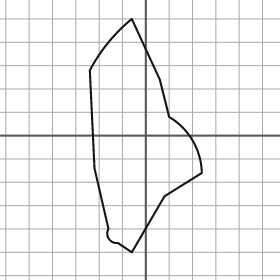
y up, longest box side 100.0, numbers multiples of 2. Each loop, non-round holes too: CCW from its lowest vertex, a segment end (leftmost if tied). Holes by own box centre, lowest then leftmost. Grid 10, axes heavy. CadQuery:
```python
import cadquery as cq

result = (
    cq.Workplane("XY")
    .moveTo(-6.0, -50.0)
    .lineTo(8.0, -26.0)
    .lineTo(24.0, -16.0)
    .threePointArc((20.0, -2.0), (10.0, 8.0))
    .lineTo(6.0, 24.0)
    .lineTo(-6.0, 50.0)
    .threePointArc((-16.0, 40.0), (-24.0, 28.0))
    .lineTo(-22.0, -14.0)
    .lineTo(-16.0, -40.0)
    .threePointArc((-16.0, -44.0), (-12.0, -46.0))
    .close()
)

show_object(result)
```